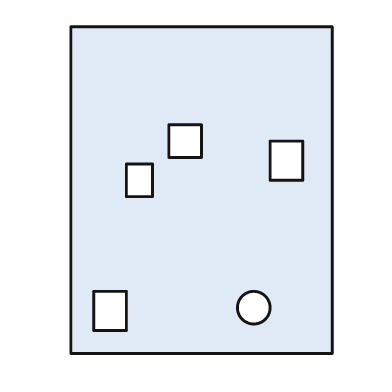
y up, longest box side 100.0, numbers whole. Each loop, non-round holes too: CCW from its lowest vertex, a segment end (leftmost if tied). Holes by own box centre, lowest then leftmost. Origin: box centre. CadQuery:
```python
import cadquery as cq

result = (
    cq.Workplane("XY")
    .moveTo(-40.0, -50.0)
    .lineTo(40.0, -50.0)
    .lineTo(40.0, 50.0)
    .lineTo(-40.0, 50.0)
    .close()
    .moveTo(-33.0, -43.0)
    .lineTo(-23.0, -43.0)
    .lineTo(-23.0, -31.0)
    .lineTo(-33.0, -31.0)
    .close()
    .moveTo(16.0, -36.0)
    .circle(5.0)
    .moveTo(-23.0, -2.0)
    .lineTo(-15.0, -2.0)
    .lineTo(-15.0, 8.0)
    .lineTo(-23.0, 8.0)
    .close()
    .moveTo(21.0, 3.0)
    .lineTo(31.0, 3.0)
    .lineTo(31.0, 15.0)
    .lineTo(21.0, 15.0)
    .close()
    .moveTo(-10.0, 10.0)
    .lineTo(0.0, 10.0)
    .lineTo(0.0, 20.0)
    .lineTo(-10.0, 20.0)
    .close()
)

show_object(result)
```